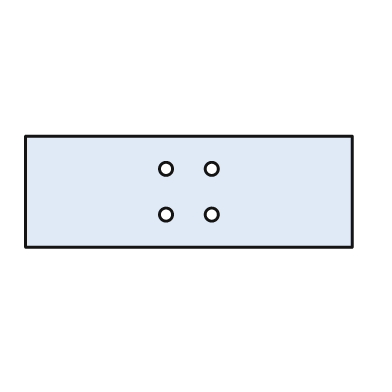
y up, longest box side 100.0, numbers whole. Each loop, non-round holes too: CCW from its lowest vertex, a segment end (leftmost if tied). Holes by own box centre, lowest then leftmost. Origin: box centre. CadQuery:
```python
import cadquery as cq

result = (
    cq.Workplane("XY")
    .moveTo(-50.0, -17.0)
    .lineTo(50.0, -17.0)
    .lineTo(50.0, 17.0)
    .lineTo(-50.0, 17.0)
    .close()
    .moveTo(-7.0, -7.0)
    .circle(2.0)
    .moveTo(7.0, -7.0)
    .circle(2.0)
    .moveTo(-7.0, 7.0)
    .circle(2.0)
    .moveTo(7.0, 7.0)
    .circle(2.0)
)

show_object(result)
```